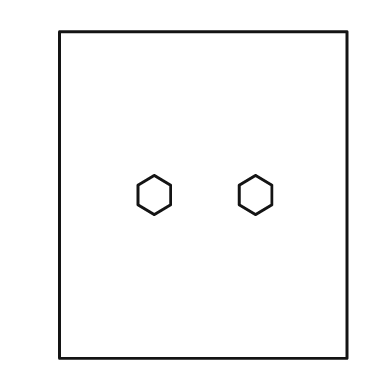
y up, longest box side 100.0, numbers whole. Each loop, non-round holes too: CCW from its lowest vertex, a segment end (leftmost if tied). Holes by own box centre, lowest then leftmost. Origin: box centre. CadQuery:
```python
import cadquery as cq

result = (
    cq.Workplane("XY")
    .moveTo(-44.0, -50.0)
    .lineTo(44.0, -50.0)
    .lineTo(44.0, 50.0)
    .lineTo(-44.0, 50.0)
    .close()
    .moveTo(-15.0, -6.0)
    .lineTo(-10.0, -3.0)
    .lineTo(-10.0, 3.0)
    .lineTo(-15.0, 6.0)
    .lineTo(-20.0, 3.0)
    .lineTo(-20.0, -3.0)
    .close()
    .moveTo(16.0, -6.0)
    .lineTo(21.0, -3.0)
    .lineTo(21.0, 3.0)
    .lineTo(16.0, 6.0)
    .lineTo(11.0, 3.0)
    .lineTo(11.0, -3.0)
    .close()
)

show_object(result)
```